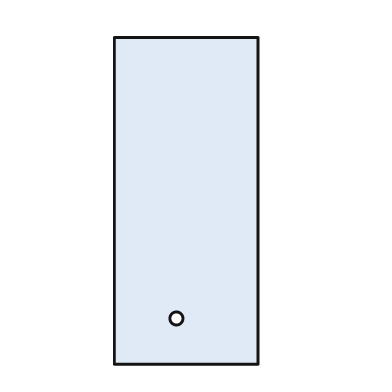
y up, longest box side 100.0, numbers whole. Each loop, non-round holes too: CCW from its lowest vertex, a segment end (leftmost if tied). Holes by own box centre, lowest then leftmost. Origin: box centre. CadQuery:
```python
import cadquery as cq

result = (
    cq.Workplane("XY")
    .moveTo(-22.0, -50.0)
    .lineTo(22.0, -50.0)
    .lineTo(22.0, 50.0)
    .lineTo(-22.0, 50.0)
    .close()
    .moveTo(-3.0, -36.0)
    .circle(2.0)
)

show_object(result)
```